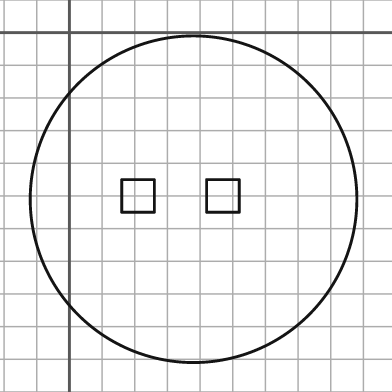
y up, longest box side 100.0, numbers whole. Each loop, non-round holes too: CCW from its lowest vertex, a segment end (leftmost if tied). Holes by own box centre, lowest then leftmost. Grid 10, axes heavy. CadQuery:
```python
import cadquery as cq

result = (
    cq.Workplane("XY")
    .moveTo(38.0, -51.0)
    .circle(50.0)
    .moveTo(16.0, -55.0)
    .lineTo(26.0, -55.0)
    .lineTo(26.0, -45.0)
    .lineTo(16.0, -45.0)
    .close()
    .moveTo(42.0, -55.0)
    .lineTo(52.0, -55.0)
    .lineTo(52.0, -45.0)
    .lineTo(42.0, -45.0)
    .close()
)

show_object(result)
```